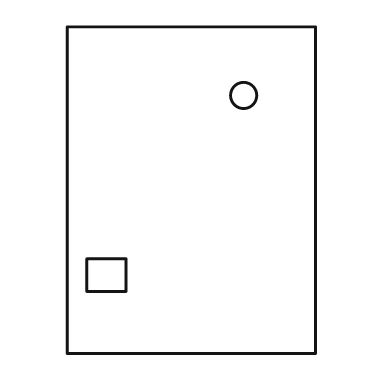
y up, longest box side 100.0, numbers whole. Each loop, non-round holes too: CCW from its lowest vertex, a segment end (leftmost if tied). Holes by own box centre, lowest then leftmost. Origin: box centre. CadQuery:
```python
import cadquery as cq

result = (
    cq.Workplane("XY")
    .moveTo(-38.0, -50.0)
    .lineTo(38.0, -50.0)
    .lineTo(38.0, 50.0)
    .lineTo(-38.0, 50.0)
    .close()
    .moveTo(-32.0, -31.0)
    .lineTo(-20.0, -31.0)
    .lineTo(-20.0, -21.0)
    .lineTo(-32.0, -21.0)
    .close()
    .moveTo(16.0, 29.0)
    .circle(4.0)
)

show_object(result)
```